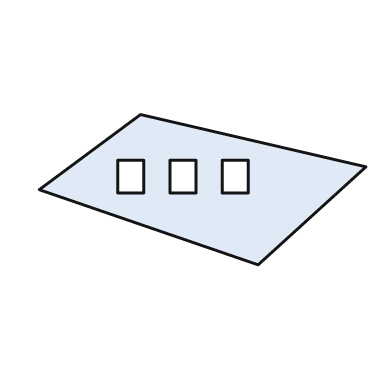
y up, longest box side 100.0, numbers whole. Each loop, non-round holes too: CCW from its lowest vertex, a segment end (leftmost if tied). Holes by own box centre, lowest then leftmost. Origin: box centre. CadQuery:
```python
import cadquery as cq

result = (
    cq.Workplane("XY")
    .moveTo(17.0, -23.0)
    .lineTo(50.0, 7.0)
    .lineTo(-19.0, 23.0)
    .lineTo(-50.0, 0.0)
    .close()
    .moveTo(-26.0, -1.0)
    .lineTo(-18.0, -1.0)
    .lineTo(-18.0, 9.0)
    .lineTo(-26.0, 9.0)
    .close()
    .moveTo(-10.0, -1.0)
    .lineTo(-2.0, -1.0)
    .lineTo(-2.0, 9.0)
    .lineTo(-10.0, 9.0)
    .close()
    .moveTo(6.0, -1.0)
    .lineTo(14.0, -1.0)
    .lineTo(14.0, 9.0)
    .lineTo(6.0, 9.0)
    .close()
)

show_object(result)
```